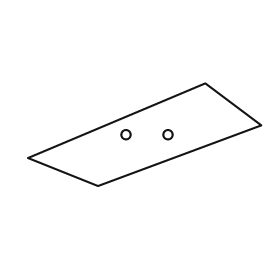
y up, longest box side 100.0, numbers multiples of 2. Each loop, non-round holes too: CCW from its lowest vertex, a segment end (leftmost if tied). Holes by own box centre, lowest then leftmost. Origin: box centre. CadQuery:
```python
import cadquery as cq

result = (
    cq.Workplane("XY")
    .moveTo(-20.0, -22.0)
    .lineTo(50.0, 4.0)
    .lineTo(26.0, 22.0)
    .lineTo(-50.0, -10.0)
    .close()
    .moveTo(-8.0, 0.0)
    .circle(2.0)
    .moveTo(10.0, 0.0)
    .circle(2.0)
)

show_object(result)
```